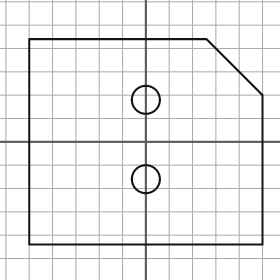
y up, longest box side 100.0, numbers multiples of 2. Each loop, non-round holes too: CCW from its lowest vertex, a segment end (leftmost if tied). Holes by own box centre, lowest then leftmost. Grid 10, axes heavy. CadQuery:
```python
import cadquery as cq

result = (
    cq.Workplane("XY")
    .moveTo(-50.0, -44.0)
    .lineTo(50.0, -44.0)
    .lineTo(50.0, 20.0)
    .lineTo(26.0, 44.0)
    .lineTo(-50.0, 44.0)
    .close()
    .moveTo(0.0, -16.0)
    .circle(6.0)
    .moveTo(0.0, 18.0)
    .circle(6.0)
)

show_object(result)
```